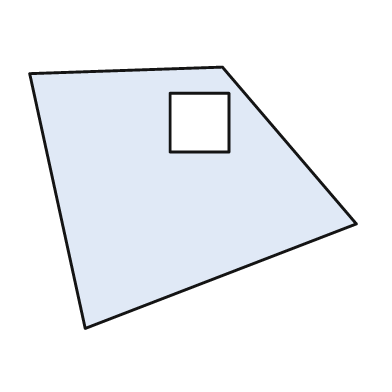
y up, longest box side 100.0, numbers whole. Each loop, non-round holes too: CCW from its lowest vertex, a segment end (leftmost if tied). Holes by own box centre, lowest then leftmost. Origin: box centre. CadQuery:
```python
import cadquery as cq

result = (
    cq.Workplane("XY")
    .moveTo(-33.0, -40.0)
    .lineTo(50.0, -8.0)
    .lineTo(9.0, 40.0)
    .lineTo(-50.0, 38.0)
    .close()
    .moveTo(-7.0, 14.0)
    .lineTo(11.0, 14.0)
    .lineTo(11.0, 32.0)
    .lineTo(-7.0, 32.0)
    .close()
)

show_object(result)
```